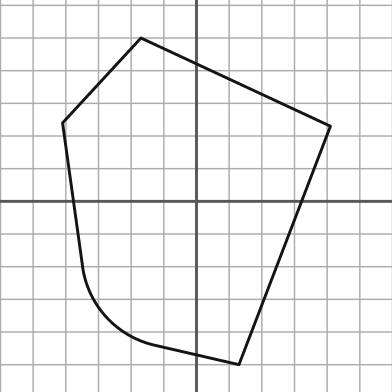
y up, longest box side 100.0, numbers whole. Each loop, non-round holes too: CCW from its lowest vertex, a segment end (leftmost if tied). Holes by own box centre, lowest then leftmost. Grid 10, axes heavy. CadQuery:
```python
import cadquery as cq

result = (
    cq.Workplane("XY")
    .moveTo(13.0, -50.0)
    .lineTo(41.0, 23.0)
    .lineTo(-17.0, 50.0)
    .lineTo(-41.0, 24.0)
    .lineTo(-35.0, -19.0)
    .threePointArc((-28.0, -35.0), (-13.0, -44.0))
    .close()
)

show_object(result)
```